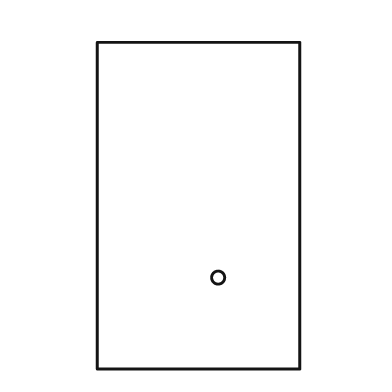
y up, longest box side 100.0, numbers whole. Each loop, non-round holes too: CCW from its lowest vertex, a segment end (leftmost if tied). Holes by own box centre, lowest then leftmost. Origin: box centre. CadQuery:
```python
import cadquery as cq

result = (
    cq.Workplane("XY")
    .moveTo(-31.0, -50.0)
    .lineTo(31.0, -50.0)
    .lineTo(31.0, 50.0)
    .lineTo(-31.0, 50.0)
    .close()
    .moveTo(6.0, -22.0)
    .circle(2.0)
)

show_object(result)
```